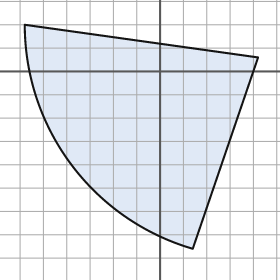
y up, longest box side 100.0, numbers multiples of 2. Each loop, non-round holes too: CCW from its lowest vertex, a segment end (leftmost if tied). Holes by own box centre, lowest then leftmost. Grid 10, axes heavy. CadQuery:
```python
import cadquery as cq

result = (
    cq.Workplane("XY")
    .moveTo(14.0, -76.0)
    .lineTo(42.0, 6.0)
    .lineTo(-58.0, 20.0)
    .threePointArc((-38.0, -40.0), (14.0, -76.0))
    .close()
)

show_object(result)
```